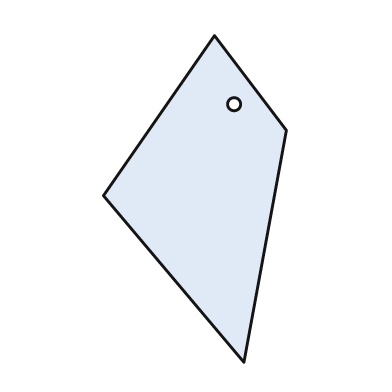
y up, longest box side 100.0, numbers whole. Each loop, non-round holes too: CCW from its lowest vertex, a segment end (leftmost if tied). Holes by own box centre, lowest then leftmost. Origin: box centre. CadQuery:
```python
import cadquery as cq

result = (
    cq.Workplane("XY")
    .moveTo(15.0, -50.0)
    .lineTo(28.0, 21.0)
    .lineTo(6.0, 50.0)
    .lineTo(-28.0, 1.0)
    .close()
    .moveTo(12.0, 29.0)
    .circle(2.0)
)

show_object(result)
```